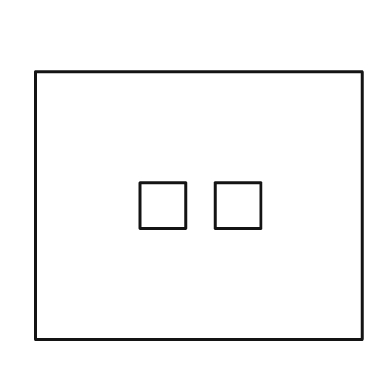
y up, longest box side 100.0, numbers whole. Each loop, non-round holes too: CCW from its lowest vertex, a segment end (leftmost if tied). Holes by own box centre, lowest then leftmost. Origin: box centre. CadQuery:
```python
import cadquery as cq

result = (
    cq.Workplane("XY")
    .moveTo(-50.0, -41.0)
    .lineTo(50.0, -41.0)
    .lineTo(50.0, 41.0)
    .lineTo(-50.0, 41.0)
    .close()
    .moveTo(-18.0, -7.0)
    .lineTo(-4.0, -7.0)
    .lineTo(-4.0, 7.0)
    .lineTo(-18.0, 7.0)
    .close()
    .moveTo(5.0, -7.0)
    .lineTo(19.0, -7.0)
    .lineTo(19.0, 7.0)
    .lineTo(5.0, 7.0)
    .close()
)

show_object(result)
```